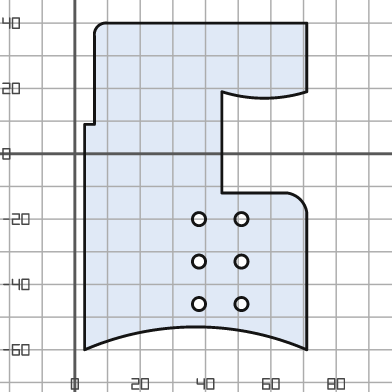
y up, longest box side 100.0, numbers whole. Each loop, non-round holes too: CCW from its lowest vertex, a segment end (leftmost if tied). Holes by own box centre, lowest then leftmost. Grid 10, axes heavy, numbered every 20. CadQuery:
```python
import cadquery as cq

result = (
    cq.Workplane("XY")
    .moveTo(3.0, -60.0)
    .threePointArc((37.0, -53.0), (71.0, -60.0))
    .lineTo(71.0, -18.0)
    .threePointArc((69.0, -14.0), (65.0, -12.0))
    .lineTo(45.0, -12.0)
    .lineTo(45.0, 19.0)
    .threePointArc((58.0, 17.0), (71.0, 19.0))
    .lineTo(71.0, 40.0)
    .lineTo(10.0, 40.0)
    .threePointArc((7.0, 39.0), (6.0, 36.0))
    .lineTo(6.0, 9.0)
    .lineTo(3.0, 9.0)
    .close()
    .moveTo(38.0, -46.0)
    .circle(2.0)
    .moveTo(51.0, -46.0)
    .circle(2.0)
    .moveTo(38.0, -33.0)
    .circle(2.0)
    .moveTo(51.0, -33.0)
    .circle(2.0)
    .moveTo(38.0, -20.0)
    .circle(2.0)
    .moveTo(51.0, -20.0)
    .circle(2.0)
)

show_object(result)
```